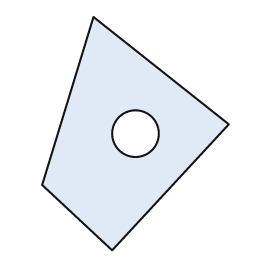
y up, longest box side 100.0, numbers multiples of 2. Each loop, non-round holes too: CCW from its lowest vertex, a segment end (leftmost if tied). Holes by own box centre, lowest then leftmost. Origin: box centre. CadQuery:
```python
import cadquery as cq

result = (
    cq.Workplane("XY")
    .moveTo(-10.0, -50.0)
    .lineTo(40.0, 4.0)
    .lineTo(-18.0, 50.0)
    .lineTo(-40.0, -22.0)
    .close()
    .moveTo(0.0, 0.0)
    .circle(10.0)
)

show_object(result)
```